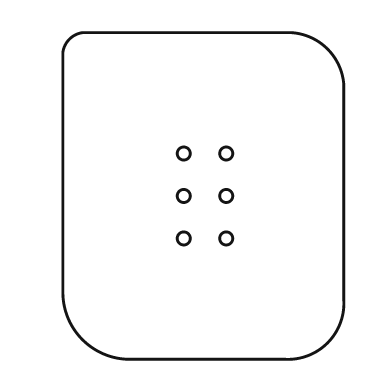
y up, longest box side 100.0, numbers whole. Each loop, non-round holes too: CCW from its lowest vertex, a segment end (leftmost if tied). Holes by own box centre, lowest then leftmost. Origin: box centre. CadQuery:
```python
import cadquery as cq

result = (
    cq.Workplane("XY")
    .moveTo(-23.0, -50.0)
    .lineTo(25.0, -50.0)
    .threePointArc((38.0, -45.0), (43.0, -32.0))
    .lineTo(43.0, 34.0)
    .threePointArc((38.0, 45.0), (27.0, 50.0))
    .lineTo(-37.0, 50.0)
    .threePointArc((-41.0, 48.0), (-43.0, 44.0))
    .lineTo(-43.0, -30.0)
    .threePointArc((-37.0, -44.0), (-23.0, -50.0))
    .close()
    .moveTo(-6.0, -13.0)
    .circle(2.0)
    .moveTo(7.0, -13.0)
    .circle(2.0)
    .moveTo(-6.0, 0.0)
    .circle(2.0)
    .moveTo(7.0, 0.0)
    .circle(2.0)
    .moveTo(-6.0, 13.0)
    .circle(2.0)
    .moveTo(7.0, 13.0)
    .circle(2.0)
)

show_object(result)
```